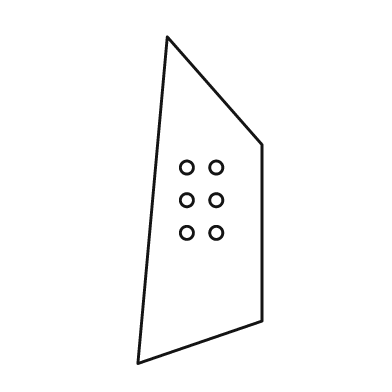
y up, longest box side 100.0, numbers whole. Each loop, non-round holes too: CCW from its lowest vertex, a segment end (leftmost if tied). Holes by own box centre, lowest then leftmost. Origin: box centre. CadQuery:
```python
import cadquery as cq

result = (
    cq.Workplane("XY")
    .moveTo(-19.0, -50.0)
    .lineTo(19.0, -37.0)
    .lineTo(19.0, 17.0)
    .lineTo(-10.0, 50.0)
    .close()
    .moveTo(-4.0, -10.0)
    .circle(2.0)
    .moveTo(5.0, -10.0)
    .circle(2.0)
    .moveTo(-4.0, 0.0)
    .circle(2.0)
    .moveTo(5.0, 0.0)
    .circle(2.0)
    .moveTo(-4.0, 10.0)
    .circle(2.0)
    .moveTo(5.0, 10.0)
    .circle(2.0)
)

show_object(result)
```